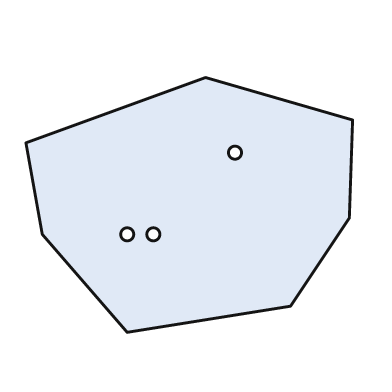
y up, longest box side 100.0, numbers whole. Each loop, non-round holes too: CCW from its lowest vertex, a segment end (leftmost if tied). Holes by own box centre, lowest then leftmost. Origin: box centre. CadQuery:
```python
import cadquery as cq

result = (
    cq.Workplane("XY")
    .moveTo(-19.0, -39.0)
    .lineTo(31.0, -31.0)
    .lineTo(49.0, -4.0)
    .lineTo(50.0, 26.0)
    .lineTo(5.0, 39.0)
    .lineTo(-50.0, 19.0)
    .lineTo(-45.0, -9.0)
    .close()
    .moveTo(-19.0, -9.0)
    .circle(2.0)
    .moveTo(-11.0, -9.0)
    .circle(2.0)
    .moveTo(14.0, 16.0)
    .circle(2.0)
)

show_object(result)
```